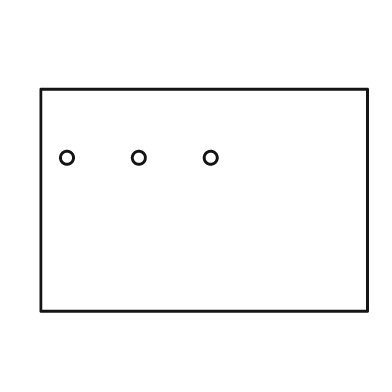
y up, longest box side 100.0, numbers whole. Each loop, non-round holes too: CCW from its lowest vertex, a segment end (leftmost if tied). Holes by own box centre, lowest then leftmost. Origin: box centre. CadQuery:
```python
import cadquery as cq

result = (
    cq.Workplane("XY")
    .moveTo(-50.0, -34.0)
    .lineTo(50.0, -34.0)
    .lineTo(50.0, 34.0)
    .lineTo(-50.0, 34.0)
    .close()
    .moveTo(-42.0, 13.0)
    .circle(2.0)
    .moveTo(-20.0, 13.0)
    .circle(2.0)
    .moveTo(2.0, 13.0)
    .circle(2.0)
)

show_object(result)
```